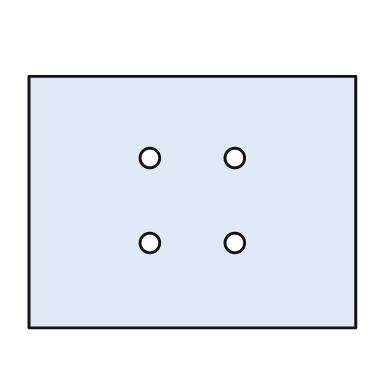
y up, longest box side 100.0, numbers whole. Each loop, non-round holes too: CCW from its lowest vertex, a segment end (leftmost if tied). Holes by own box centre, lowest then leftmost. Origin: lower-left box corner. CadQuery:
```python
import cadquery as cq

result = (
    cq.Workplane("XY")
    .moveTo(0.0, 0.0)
    .lineTo(100.0, 0.0)
    .lineTo(100.0, 77.0)
    .lineTo(0.0, 77.0)
    .close()
    .moveTo(37.0, 26.0)
    .circle(3.0)
    .moveTo(63.0, 26.0)
    .circle(3.0)
    .moveTo(37.0, 52.0)
    .circle(3.0)
    .moveTo(63.0, 52.0)
    .circle(3.0)
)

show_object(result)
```